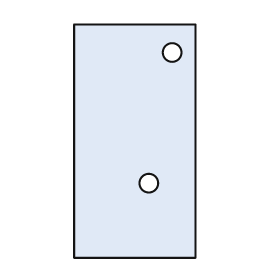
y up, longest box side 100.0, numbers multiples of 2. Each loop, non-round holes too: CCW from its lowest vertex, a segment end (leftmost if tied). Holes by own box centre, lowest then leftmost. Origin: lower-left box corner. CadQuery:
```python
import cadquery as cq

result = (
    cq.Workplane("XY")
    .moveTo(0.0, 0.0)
    .lineTo(52.0, 0.0)
    .lineTo(52.0, 100.0)
    .lineTo(0.0, 100.0)
    .close()
    .moveTo(32.0, 32.0)
    .circle(4.0)
    .moveTo(42.0, 88.0)
    .circle(4.0)
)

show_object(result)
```